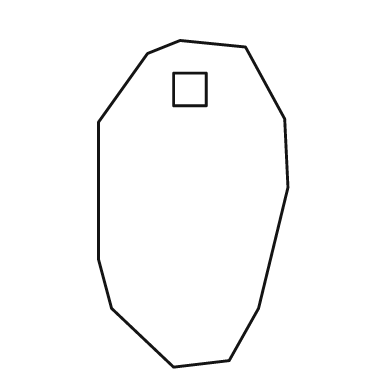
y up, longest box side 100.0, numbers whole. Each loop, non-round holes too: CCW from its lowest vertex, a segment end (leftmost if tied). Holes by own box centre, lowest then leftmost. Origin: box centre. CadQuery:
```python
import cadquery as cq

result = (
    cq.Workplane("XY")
    .moveTo(-6.0, -50.0)
    .lineTo(11.0, -48.0)
    .lineTo(20.0, -32.0)
    .lineTo(29.0, 5.0)
    .lineTo(28.0, 26.0)
    .lineTo(16.0, 48.0)
    .lineTo(-4.0, 50.0)
    .lineTo(-14.0, 46.0)
    .lineTo(-29.0, 25.0)
    .lineTo(-29.0, -17.0)
    .lineTo(-25.0, -32.0)
    .close()
    .moveTo(-6.0, 30.0)
    .lineTo(4.0, 30.0)
    .lineTo(4.0, 40.0)
    .lineTo(-6.0, 40.0)
    .close()
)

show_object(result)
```